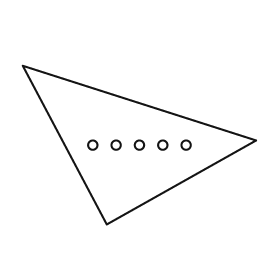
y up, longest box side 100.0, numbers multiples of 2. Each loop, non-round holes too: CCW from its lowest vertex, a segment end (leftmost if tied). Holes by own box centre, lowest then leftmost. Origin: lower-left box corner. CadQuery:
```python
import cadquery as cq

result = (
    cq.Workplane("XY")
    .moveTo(36.0, 0.0)
    .lineTo(100.0, 36.0)
    .lineTo(0.0, 68.0)
    .close()
    .moveTo(30.0, 34.0)
    .circle(2.0)
    .moveTo(40.0, 34.0)
    .circle(2.0)
    .moveTo(50.0, 34.0)
    .circle(2.0)
    .moveTo(60.0, 34.0)
    .circle(2.0)
    .moveTo(70.0, 34.0)
    .circle(2.0)
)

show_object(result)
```